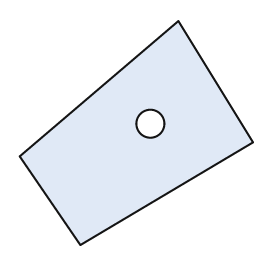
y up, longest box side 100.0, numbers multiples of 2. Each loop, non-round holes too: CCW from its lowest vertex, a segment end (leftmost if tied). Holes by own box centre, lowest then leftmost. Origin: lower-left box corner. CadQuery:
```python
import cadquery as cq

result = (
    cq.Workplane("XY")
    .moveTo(26.0, 0.0)
    .lineTo(100.0, 44.0)
    .lineTo(68.0, 96.0)
    .lineTo(0.0, 38.0)
    .close()
    .moveTo(56.0, 52.0)
    .circle(6.0)
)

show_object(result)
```